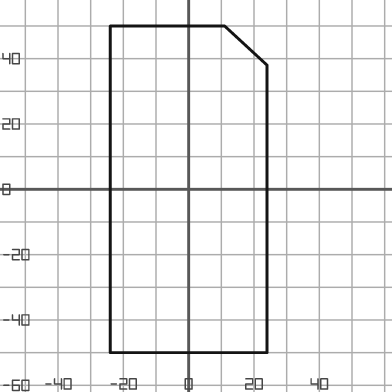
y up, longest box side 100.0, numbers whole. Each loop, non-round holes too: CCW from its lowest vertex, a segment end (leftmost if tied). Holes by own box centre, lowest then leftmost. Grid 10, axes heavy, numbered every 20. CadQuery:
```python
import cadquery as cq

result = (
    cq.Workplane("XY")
    .moveTo(-24.0, -50.0)
    .lineTo(24.0, -50.0)
    .lineTo(24.0, 38.0)
    .lineTo(11.0, 50.0)
    .lineTo(-24.0, 50.0)
    .close()
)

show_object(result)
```